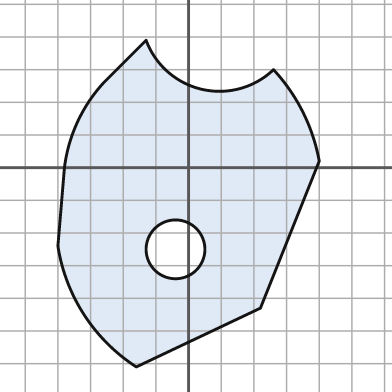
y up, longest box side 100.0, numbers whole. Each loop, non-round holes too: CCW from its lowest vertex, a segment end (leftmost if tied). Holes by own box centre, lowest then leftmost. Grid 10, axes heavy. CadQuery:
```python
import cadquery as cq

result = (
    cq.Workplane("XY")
    .moveTo(-16.0, -61.0)
    .lineTo(22.0, -43.0)
    .lineTo(40.0, 2.0)
    .threePointArc((35.0, 17.0), (26.0, 30.0))
    .threePointArc((4.0, 24.0), (-13.0, 39.0))
    .lineTo(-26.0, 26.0)
    .threePointArc((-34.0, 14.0), (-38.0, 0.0))
    .lineTo(-40.0, -24.0)
    .threePointArc((-32.0, -45.0), (-16.0, -61.0))
    .close()
    .moveTo(-4.0, -25.0)
    .circle(9.0)
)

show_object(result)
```